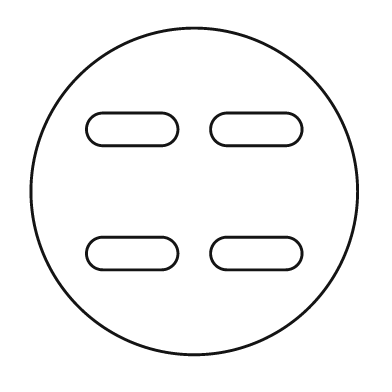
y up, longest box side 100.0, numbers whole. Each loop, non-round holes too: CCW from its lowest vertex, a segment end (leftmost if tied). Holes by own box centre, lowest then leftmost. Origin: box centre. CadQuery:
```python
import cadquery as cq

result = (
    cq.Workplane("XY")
    .moveTo(0.0, 0.0)
    .circle(50.0)
    .moveTo(-28.0, -24.0)
    .lineTo(-10.0, -24.0)
    .threePointArc((-5.0, -19.0), (-10.0, -14.0))
    .lineTo(-28.0, -14.0)
    .threePointArc((-33.0, -19.0), (-28.0, -24.0))
    .close()
    .moveTo(10.0, -24.0)
    .lineTo(28.0, -24.0)
    .threePointArc((33.0, -19.0), (28.0, -14.0))
    .lineTo(10.0, -14.0)
    .threePointArc((5.0, -19.0), (10.0, -24.0))
    .close()
    .moveTo(-28.0, 14.0)
    .lineTo(-10.0, 14.0)
    .threePointArc((-5.0, 19.0), (-10.0, 24.0))
    .lineTo(-28.0, 24.0)
    .threePointArc((-33.0, 19.0), (-28.0, 14.0))
    .close()
    .moveTo(10.0, 14.0)
    .lineTo(28.0, 14.0)
    .threePointArc((33.0, 19.0), (28.0, 24.0))
    .lineTo(10.0, 24.0)
    .threePointArc((5.0, 19.0), (10.0, 14.0))
    .close()
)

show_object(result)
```